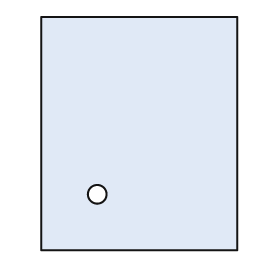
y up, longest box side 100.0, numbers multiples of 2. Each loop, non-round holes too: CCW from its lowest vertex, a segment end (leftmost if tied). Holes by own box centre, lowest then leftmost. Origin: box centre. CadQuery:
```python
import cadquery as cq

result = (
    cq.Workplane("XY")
    .moveTo(-42.0, -50.0)
    .lineTo(42.0, -50.0)
    .lineTo(42.0, 50.0)
    .lineTo(-42.0, 50.0)
    .close()
    .moveTo(-18.0, -26.0)
    .circle(4.0)
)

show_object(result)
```